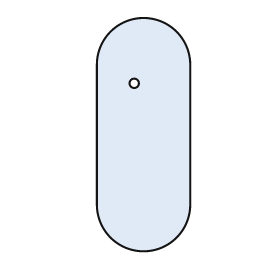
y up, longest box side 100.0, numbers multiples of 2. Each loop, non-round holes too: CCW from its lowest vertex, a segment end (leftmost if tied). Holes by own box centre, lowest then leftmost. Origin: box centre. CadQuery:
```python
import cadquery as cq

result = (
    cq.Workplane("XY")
    .moveTo(-20.0, -30.0)
    .threePointArc((0.0, -50.0), (20.0, -30.0))
    .lineTo(20.0, 30.0)
    .threePointArc((0.0, 50.0), (-20.0, 30.0))
    .close()
    .moveTo(-4.0, 22.0)
    .circle(2.0)
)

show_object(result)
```